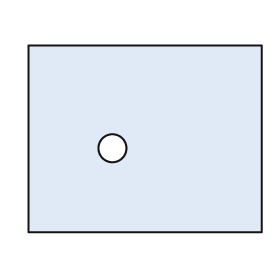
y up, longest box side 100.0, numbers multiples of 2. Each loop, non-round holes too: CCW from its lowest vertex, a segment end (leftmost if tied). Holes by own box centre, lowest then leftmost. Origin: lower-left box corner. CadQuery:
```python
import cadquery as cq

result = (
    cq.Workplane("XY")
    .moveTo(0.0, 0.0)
    .lineTo(100.0, 0.0)
    .lineTo(100.0, 80.0)
    .lineTo(0.0, 80.0)
    .close()
    .moveTo(36.0, 36.0)
    .circle(6.0)
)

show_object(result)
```